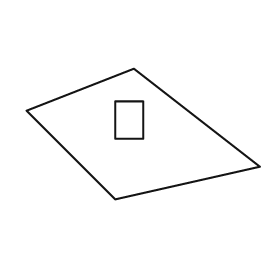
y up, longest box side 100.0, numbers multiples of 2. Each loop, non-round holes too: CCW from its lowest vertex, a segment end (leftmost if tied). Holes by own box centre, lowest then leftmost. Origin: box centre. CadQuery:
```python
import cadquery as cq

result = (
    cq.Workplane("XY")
    .moveTo(-12.0, -28.0)
    .lineTo(50.0, -14.0)
    .lineTo(-4.0, 28.0)
    .lineTo(-50.0, 10.0)
    .close()
    .moveTo(-12.0, -2.0)
    .lineTo(0.0, -2.0)
    .lineTo(0.0, 14.0)
    .lineTo(-12.0, 14.0)
    .close()
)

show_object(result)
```